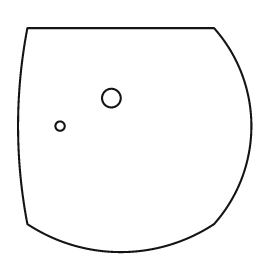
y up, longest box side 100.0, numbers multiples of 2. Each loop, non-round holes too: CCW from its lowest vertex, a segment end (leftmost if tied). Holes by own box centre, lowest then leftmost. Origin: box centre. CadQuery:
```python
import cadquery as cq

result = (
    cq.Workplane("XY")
    .moveTo(-46.0, -36.0)
    .threePointArc((-6.0, -48.0), (34.0, -36.0))
    .threePointArc((50.0, 6.0), (34.0, 48.0))
    .lineTo(-46.0, 48.0)
    .threePointArc((-50.0, 6.0), (-46.0, -36.0))
    .close()
    .moveTo(-32.0, 6.0)
    .circle(2.0)
    .moveTo(-10.0, 18.0)
    .circle(4.0)
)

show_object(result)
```